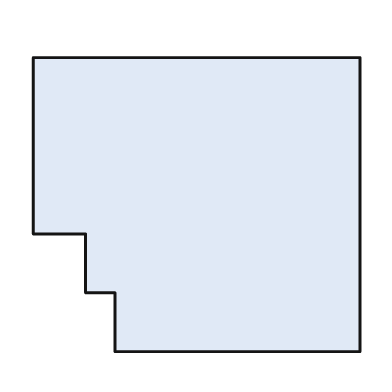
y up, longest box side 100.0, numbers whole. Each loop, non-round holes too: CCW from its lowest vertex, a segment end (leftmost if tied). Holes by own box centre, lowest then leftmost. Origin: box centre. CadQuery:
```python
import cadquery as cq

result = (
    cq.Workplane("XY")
    .moveTo(-25.0, -45.0)
    .lineTo(50.0, -45.0)
    .lineTo(50.0, 45.0)
    .lineTo(-50.0, 45.0)
    .lineTo(-50.0, -9.0)
    .lineTo(-34.0, -9.0)
    .lineTo(-34.0, -27.0)
    .lineTo(-25.0, -27.0)
    .close()
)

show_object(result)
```